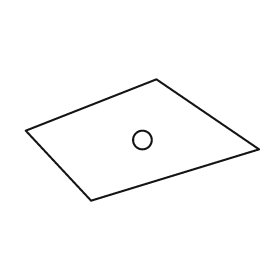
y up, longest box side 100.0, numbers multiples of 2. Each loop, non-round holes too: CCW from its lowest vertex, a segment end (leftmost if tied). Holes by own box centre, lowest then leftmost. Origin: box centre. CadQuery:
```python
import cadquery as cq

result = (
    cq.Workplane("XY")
    .moveTo(-22.0, -26.0)
    .lineTo(50.0, -4.0)
    .lineTo(6.0, 26.0)
    .lineTo(-50.0, 4.0)
    .close()
    .moveTo(0.0, 0.0)
    .circle(4.0)
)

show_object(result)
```